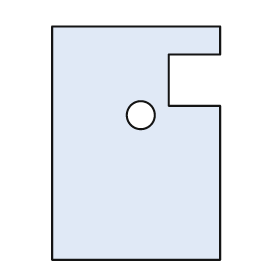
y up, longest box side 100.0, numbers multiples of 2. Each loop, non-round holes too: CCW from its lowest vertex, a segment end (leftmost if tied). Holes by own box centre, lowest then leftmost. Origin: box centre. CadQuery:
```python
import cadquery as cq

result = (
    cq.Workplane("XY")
    .moveTo(-36.0, -50.0)
    .lineTo(36.0, -50.0)
    .lineTo(36.0, 16.0)
    .lineTo(14.0, 16.0)
    .lineTo(14.0, 38.0)
    .lineTo(36.0, 38.0)
    .lineTo(36.0, 50.0)
    .lineTo(-36.0, 50.0)
    .close()
    .moveTo(2.0, 12.0)
    .circle(6.0)
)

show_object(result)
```